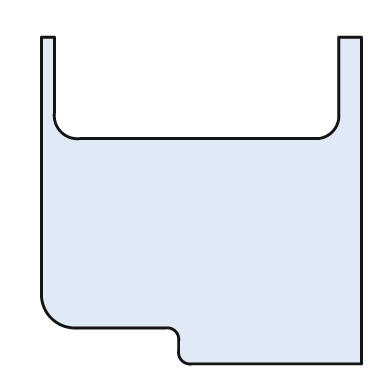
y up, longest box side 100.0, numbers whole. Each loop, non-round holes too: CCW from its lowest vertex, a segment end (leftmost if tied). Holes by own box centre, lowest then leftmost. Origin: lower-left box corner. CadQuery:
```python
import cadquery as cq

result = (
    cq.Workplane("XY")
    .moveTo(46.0, 0.0)
    .lineTo(98.0, 0.0)
    .lineTo(98.0, 100.0)
    .lineTo(91.0, 100.0)
    .lineTo(91.0, 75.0)
    .threePointArc((89.0, 71.0), (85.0, 69.0))
    .lineTo(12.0, 69.0)
    .threePointArc((6.0, 71.0), (4.0, 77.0))
    .lineTo(4.0, 100.0)
    .lineTo(0.0, 100.0)
    .lineTo(0.0, 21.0)
    .threePointArc((3.0, 14.0), (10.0, 11.0))
    .lineTo(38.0, 11.0)
    .threePointArc((41.0, 10.0), (42.0, 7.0))
    .lineTo(42.0, 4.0)
    .threePointArc((43.0, 1.0), (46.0, 0.0))
    .close()
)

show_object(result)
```